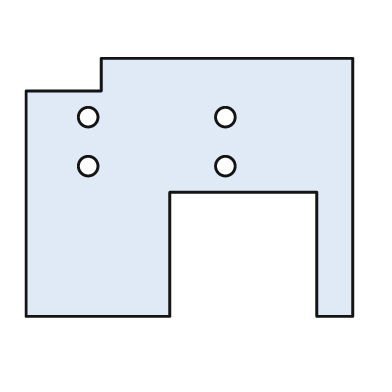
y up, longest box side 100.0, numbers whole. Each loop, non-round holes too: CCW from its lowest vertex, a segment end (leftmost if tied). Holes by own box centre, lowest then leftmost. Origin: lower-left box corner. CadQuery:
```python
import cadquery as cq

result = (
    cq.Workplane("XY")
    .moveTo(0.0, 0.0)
    .lineTo(44.0, 0.0)
    .lineTo(44.0, 38.0)
    .lineTo(89.0, 38.0)
    .lineTo(89.0, 0.0)
    .lineTo(100.0, 0.0)
    .lineTo(100.0, 79.0)
    .lineTo(23.0, 79.0)
    .lineTo(23.0, 69.0)
    .lineTo(0.0, 69.0)
    .close()
    .moveTo(19.0, 46.0)
    .circle(3.0)
    .moveTo(61.0, 46.0)
    .circle(3.0)
    .moveTo(19.0, 61.0)
    .circle(3.0)
    .moveTo(61.0, 61.0)
    .circle(3.0)
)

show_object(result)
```